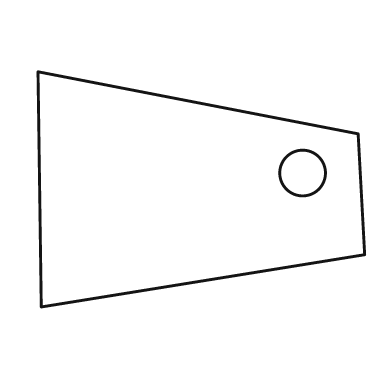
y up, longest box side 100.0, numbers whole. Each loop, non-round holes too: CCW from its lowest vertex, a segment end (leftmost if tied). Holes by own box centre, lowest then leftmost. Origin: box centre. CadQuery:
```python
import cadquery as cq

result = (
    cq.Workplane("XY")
    .moveTo(-49.0, -36.0)
    .lineTo(50.0, -20.0)
    .lineTo(48.0, 17.0)
    .lineTo(-50.0, 36.0)
    .close()
    .moveTo(31.0, 5.0)
    .circle(7.0)
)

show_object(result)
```